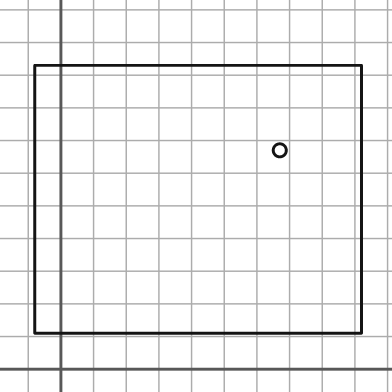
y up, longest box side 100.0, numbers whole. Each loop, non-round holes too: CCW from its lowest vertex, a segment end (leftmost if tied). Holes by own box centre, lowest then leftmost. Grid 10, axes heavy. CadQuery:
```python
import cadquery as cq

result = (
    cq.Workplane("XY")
    .moveTo(-8.0, 11.0)
    .lineTo(92.0, 11.0)
    .lineTo(92.0, 93.0)
    .lineTo(-8.0, 93.0)
    .close()
    .moveTo(67.0, 67.0)
    .circle(2.0)
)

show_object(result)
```